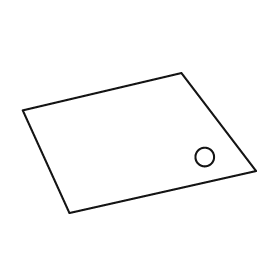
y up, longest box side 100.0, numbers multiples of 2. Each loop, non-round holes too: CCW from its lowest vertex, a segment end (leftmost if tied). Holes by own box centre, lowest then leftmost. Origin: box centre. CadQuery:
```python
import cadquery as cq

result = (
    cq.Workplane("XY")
    .moveTo(-30.0, -30.0)
    .lineTo(50.0, -12.0)
    .lineTo(18.0, 30.0)
    .lineTo(-50.0, 14.0)
    .close()
    .moveTo(28.0, -6.0)
    .circle(4.0)
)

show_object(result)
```